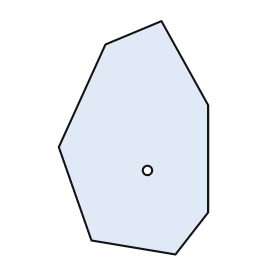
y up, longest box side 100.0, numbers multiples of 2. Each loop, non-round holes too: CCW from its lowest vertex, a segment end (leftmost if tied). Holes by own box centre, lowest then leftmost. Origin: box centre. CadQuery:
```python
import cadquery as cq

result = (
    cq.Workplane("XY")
    .moveTo(18.0, -50.0)
    .lineTo(32.0, -32.0)
    .lineTo(32.0, 14.0)
    .lineTo(12.0, 50.0)
    .lineTo(-12.0, 40.0)
    .lineTo(-32.0, -4.0)
    .lineTo(-18.0, -44.0)
    .close()
    .moveTo(6.0, -14.0)
    .circle(2.0)
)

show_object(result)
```